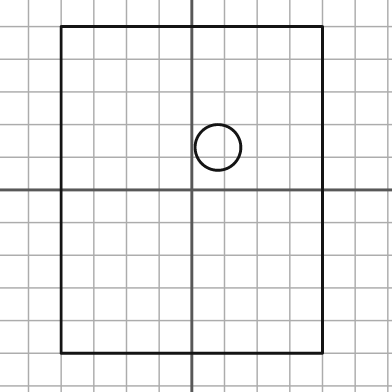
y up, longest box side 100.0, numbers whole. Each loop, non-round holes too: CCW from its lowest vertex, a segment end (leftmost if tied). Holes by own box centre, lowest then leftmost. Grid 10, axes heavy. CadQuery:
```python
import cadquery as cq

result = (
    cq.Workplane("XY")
    .moveTo(-40.0, -50.0)
    .lineTo(40.0, -50.0)
    .lineTo(40.0, 50.0)
    .lineTo(-40.0, 50.0)
    .close()
    .moveTo(8.0, 13.0)
    .circle(7.0)
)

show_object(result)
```